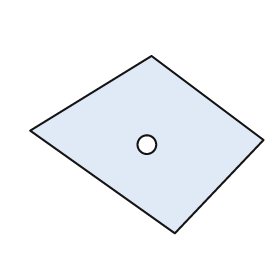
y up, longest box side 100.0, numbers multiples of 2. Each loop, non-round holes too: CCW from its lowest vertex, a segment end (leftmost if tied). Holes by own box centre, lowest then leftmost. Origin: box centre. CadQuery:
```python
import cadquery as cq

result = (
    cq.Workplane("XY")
    .moveTo(12.0, -38.0)
    .lineTo(50.0, 2.0)
    .lineTo(2.0, 38.0)
    .lineTo(-50.0, 6.0)
    .close()
    .moveTo(0.0, 0.0)
    .circle(4.0)
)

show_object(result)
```